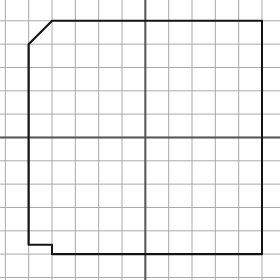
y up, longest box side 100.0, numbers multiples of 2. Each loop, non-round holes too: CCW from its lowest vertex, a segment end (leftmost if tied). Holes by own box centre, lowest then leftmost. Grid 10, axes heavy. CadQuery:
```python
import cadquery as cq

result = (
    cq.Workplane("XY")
    .moveTo(-40.0, -50.0)
    .lineTo(50.0, -50.0)
    .lineTo(50.0, 50.0)
    .lineTo(-40.0, 50.0)
    .lineTo(-50.0, 40.0)
    .lineTo(-50.0, -46.0)
    .lineTo(-40.0, -46.0)
    .close()
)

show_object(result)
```